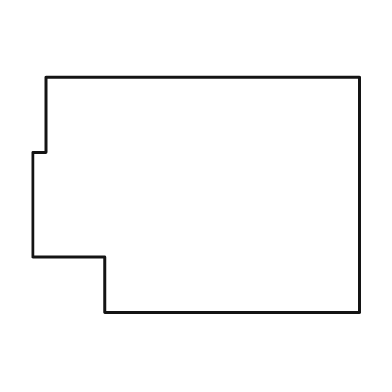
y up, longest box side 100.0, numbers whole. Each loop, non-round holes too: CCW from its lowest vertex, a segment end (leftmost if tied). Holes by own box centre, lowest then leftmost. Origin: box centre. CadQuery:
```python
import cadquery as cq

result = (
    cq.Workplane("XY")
    .moveTo(-28.0, -36.0)
    .lineTo(50.0, -36.0)
    .lineTo(50.0, 36.0)
    .lineTo(-46.0, 36.0)
    .lineTo(-46.0, 13.0)
    .lineTo(-50.0, 13.0)
    .lineTo(-50.0, -19.0)
    .lineTo(-28.0, -19.0)
    .close()
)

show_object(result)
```